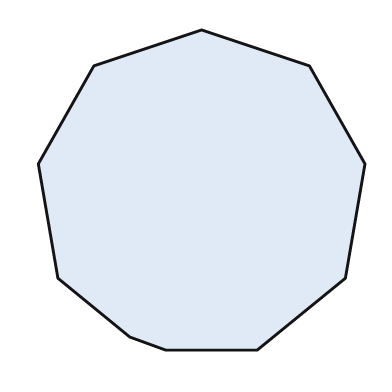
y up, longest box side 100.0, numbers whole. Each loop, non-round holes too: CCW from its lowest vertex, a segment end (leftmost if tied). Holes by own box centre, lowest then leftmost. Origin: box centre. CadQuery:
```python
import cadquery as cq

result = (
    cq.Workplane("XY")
    .moveTo(-11.0, -49.0)
    .lineTo(17.0, -49.0)
    .lineTo(44.0, -27.0)
    .lineTo(50.0, 8.0)
    .lineTo(33.0, 38.0)
    .lineTo(0.0, 49.0)
    .lineTo(-33.0, 38.0)
    .lineTo(-50.0, 8.0)
    .lineTo(-44.0, -27.0)
    .lineTo(-22.0, -45.0)
    .close()
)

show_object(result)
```